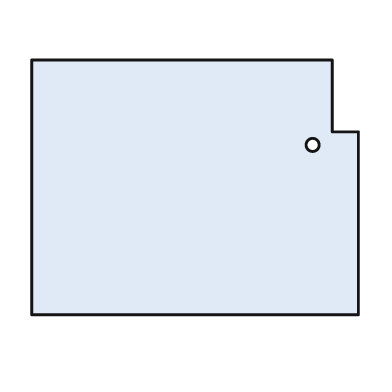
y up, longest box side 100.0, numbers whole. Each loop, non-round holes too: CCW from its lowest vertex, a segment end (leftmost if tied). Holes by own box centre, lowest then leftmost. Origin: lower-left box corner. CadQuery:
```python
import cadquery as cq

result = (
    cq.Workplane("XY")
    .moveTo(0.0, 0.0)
    .lineTo(100.0, 0.0)
    .lineTo(100.0, 56.0)
    .lineTo(92.0, 56.0)
    .lineTo(92.0, 78.0)
    .lineTo(0.0, 78.0)
    .close()
    .moveTo(86.0, 52.0)
    .circle(2.0)
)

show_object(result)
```